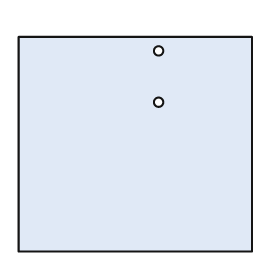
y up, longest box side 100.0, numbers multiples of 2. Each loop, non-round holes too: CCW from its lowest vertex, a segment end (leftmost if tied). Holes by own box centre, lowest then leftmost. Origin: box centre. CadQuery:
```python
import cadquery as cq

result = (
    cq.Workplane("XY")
    .moveTo(-50.0, -46.0)
    .lineTo(50.0, -46.0)
    .lineTo(50.0, 46.0)
    .lineTo(-50.0, 46.0)
    .close()
    .moveTo(10.0, 18.0)
    .circle(2.0)
    .moveTo(10.0, 40.0)
    .circle(2.0)
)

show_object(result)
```